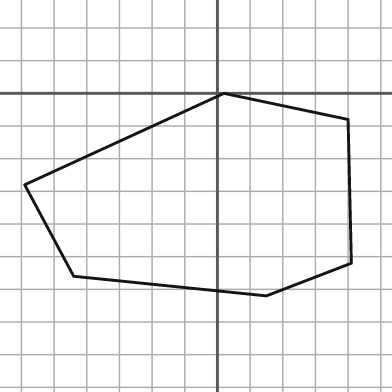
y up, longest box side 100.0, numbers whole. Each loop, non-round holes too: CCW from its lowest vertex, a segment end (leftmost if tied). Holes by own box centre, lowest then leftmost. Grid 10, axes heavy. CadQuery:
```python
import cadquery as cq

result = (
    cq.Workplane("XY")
    .moveTo(15.0, -62.0)
    .lineTo(41.0, -52.0)
    .lineTo(40.0, -8.0)
    .lineTo(2.0, 0.0)
    .lineTo(-59.0, -28.0)
    .lineTo(-44.0, -56.0)
    .close()
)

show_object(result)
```